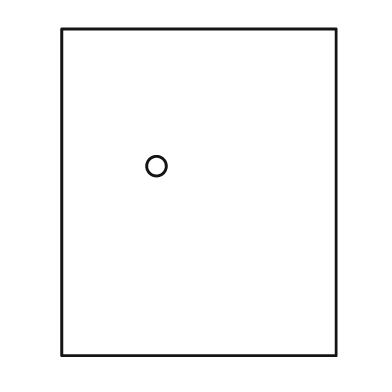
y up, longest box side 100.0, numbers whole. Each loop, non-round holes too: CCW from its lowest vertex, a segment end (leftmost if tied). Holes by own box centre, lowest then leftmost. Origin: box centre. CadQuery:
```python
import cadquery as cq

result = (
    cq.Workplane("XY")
    .moveTo(-42.0, -50.0)
    .lineTo(42.0, -50.0)
    .lineTo(42.0, 50.0)
    .lineTo(-42.0, 50.0)
    .close()
    .moveTo(-13.0, 8.0)
    .circle(3.0)
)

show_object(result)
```